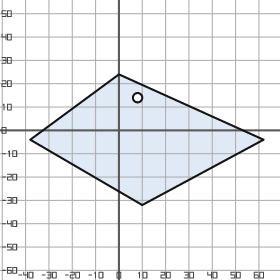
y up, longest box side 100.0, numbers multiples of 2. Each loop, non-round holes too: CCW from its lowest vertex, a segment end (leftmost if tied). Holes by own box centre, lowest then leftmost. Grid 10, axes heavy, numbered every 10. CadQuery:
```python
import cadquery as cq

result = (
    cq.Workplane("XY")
    .moveTo(10.0, -32.0)
    .lineTo(62.0, -4.0)
    .lineTo(0.0, 24.0)
    .lineTo(-38.0, -4.0)
    .close()
    .moveTo(8.0, 14.0)
    .circle(2.0)
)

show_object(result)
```